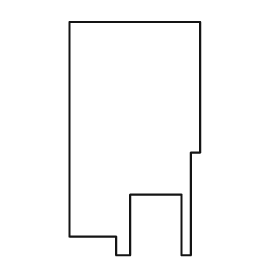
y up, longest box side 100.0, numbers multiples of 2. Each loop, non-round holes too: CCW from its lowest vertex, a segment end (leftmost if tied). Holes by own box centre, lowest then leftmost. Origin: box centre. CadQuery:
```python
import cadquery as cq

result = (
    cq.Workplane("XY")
    .moveTo(-8.0, -50.0)
    .lineTo(-2.0, -50.0)
    .lineTo(-2.0, -24.0)
    .lineTo(20.0, -24.0)
    .lineTo(20.0, -50.0)
    .lineTo(24.0, -50.0)
    .lineTo(24.0, -6.0)
    .lineTo(28.0, -6.0)
    .lineTo(28.0, 50.0)
    .lineTo(-28.0, 50.0)
    .lineTo(-28.0, -42.0)
    .lineTo(-8.0, -42.0)
    .close()
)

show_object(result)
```